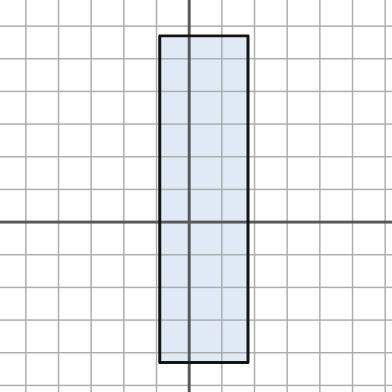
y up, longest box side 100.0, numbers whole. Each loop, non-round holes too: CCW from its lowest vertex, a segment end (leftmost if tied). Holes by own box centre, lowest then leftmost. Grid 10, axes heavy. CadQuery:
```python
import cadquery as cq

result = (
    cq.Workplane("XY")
    .moveTo(-9.0, -43.0)
    .lineTo(18.0, -43.0)
    .lineTo(18.0, 57.0)
    .lineTo(-9.0, 57.0)
    .close()
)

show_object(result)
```